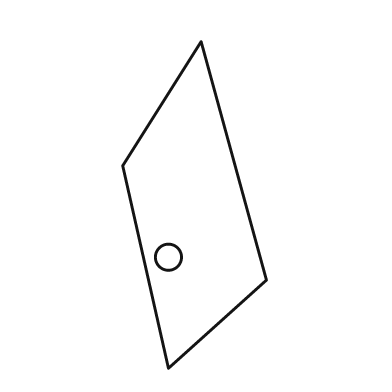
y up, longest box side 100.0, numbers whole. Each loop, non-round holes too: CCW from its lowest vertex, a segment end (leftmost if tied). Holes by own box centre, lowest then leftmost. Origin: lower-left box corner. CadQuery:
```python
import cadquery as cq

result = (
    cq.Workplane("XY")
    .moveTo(14.0, 0.0)
    .lineTo(44.0, 27.0)
    .lineTo(24.0, 100.0)
    .lineTo(0.0, 62.0)
    .close()
    .moveTo(14.0, 34.0)
    .circle(4.0)
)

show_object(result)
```